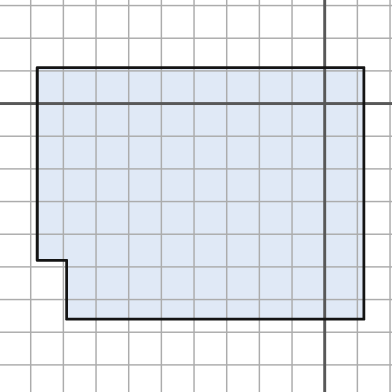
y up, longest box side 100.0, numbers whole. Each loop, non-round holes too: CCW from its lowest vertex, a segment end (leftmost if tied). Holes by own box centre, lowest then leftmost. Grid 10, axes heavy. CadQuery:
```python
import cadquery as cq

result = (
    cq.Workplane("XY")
    .moveTo(-79.0, -66.0)
    .lineTo(12.0, -66.0)
    .lineTo(12.0, 11.0)
    .lineTo(-88.0, 11.0)
    .lineTo(-88.0, -48.0)
    .lineTo(-79.0, -48.0)
    .close()
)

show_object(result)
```